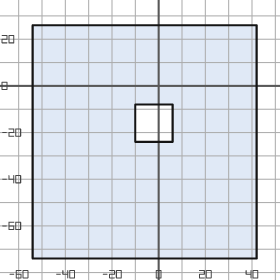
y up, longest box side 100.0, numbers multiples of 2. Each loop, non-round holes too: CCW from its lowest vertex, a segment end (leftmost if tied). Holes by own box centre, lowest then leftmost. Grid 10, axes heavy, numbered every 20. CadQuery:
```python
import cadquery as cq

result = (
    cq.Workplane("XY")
    .moveTo(-54.0, -74.0)
    .lineTo(42.0, -74.0)
    .lineTo(42.0, 26.0)
    .lineTo(-54.0, 26.0)
    .close()
    .moveTo(-10.0, -24.0)
    .lineTo(6.0, -24.0)
    .lineTo(6.0, -8.0)
    .lineTo(-10.0, -8.0)
    .close()
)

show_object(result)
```